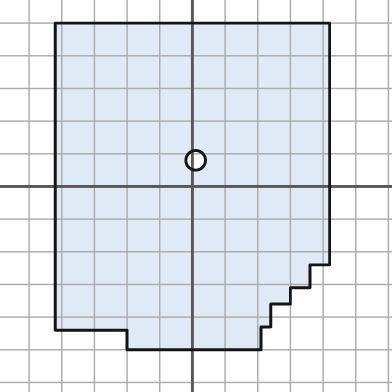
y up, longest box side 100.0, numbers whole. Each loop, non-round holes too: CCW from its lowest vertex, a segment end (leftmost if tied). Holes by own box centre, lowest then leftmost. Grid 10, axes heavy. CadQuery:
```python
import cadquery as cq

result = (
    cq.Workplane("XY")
    .moveTo(-20.0, -50.0)
    .lineTo(21.0, -50.0)
    .lineTo(21.0, -43.0)
    .lineTo(24.0, -43.0)
    .lineTo(24.0, -36.0)
    .lineTo(30.0, -36.0)
    .lineTo(30.0, -31.0)
    .lineTo(36.0, -31.0)
    .lineTo(36.0, -24.0)
    .lineTo(42.0, -24.0)
    .lineTo(42.0, 50.0)
    .lineTo(-42.0, 50.0)
    .lineTo(-42.0, -44.0)
    .lineTo(-20.0, -44.0)
    .close()
    .moveTo(1.0, 8.0)
    .circle(3.0)
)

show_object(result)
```